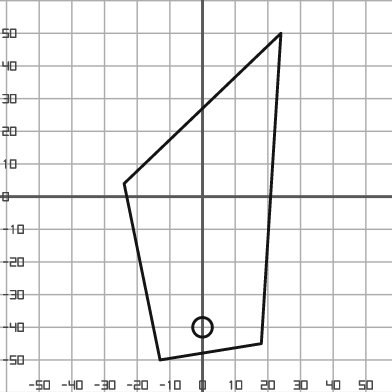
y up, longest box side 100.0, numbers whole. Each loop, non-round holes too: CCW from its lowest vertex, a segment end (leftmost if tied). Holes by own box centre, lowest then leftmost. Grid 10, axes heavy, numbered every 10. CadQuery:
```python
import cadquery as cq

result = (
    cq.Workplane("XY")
    .moveTo(-13.0, -50.0)
    .lineTo(18.0, -45.0)
    .lineTo(24.0, 50.0)
    .lineTo(-24.0, 4.0)
    .close()
    .moveTo(0.0, -40.0)
    .circle(3.0)
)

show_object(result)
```